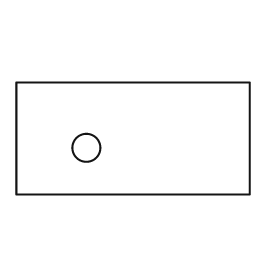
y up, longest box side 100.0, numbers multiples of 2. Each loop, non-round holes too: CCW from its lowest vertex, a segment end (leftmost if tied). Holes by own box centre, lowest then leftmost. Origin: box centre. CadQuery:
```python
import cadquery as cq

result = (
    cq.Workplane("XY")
    .moveTo(-50.0, -24.0)
    .lineTo(50.0, -24.0)
    .lineTo(50.0, 24.0)
    .lineTo(-50.0, 24.0)
    .close()
    .moveTo(-20.0, -4.0)
    .circle(6.0)
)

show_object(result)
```